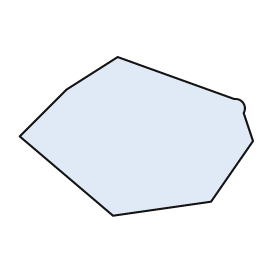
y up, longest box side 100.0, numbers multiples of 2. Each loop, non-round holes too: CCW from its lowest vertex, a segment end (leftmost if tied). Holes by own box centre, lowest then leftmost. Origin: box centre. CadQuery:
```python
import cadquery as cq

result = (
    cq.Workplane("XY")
    .moveTo(-10.0, -34.0)
    .lineTo(32.0, -28.0)
    .lineTo(50.0, -2.0)
    .lineTo(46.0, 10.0)
    .threePointArc((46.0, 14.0), (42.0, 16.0))
    .lineTo(-8.0, 34.0)
    .lineTo(-30.0, 20.0)
    .lineTo(-50.0, 0.0)
    .close()
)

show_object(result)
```